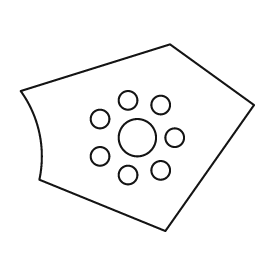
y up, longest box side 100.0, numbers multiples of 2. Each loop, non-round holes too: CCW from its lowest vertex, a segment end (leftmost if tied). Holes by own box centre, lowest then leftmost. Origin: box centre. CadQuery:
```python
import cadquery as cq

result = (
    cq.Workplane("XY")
    .moveTo(12.0, -40.0)
    .lineTo(50.0, 14.0)
    .lineTo(14.0, 40.0)
    .lineTo(-50.0, 20.0)
    .threePointArc((-42.0, 2.0), (-42.0, -18.0))
    .close()
    .moveTo(-4.0, -16.0)
    .circle(4.0)
    .moveTo(10.0, -14.0)
    .circle(4.0)
    .moveTo(-16.0, -8.0)
    .circle(4.0)
    .moveTo(0.0, 0.0)
    .circle(8.0)
    .moveTo(16.0, 0.0)
    .circle(4.0)
    .moveTo(-16.0, 8.0)
    .circle(4.0)
    .moveTo(10.0, 14.0)
    .circle(4.0)
    .moveTo(-4.0, 16.0)
    .circle(4.0)
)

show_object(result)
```